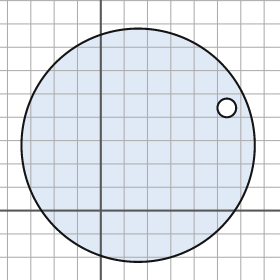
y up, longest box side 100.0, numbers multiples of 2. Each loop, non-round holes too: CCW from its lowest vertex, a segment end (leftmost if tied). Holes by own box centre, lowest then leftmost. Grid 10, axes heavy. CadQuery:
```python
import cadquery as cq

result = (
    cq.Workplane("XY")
    .moveTo(16.0, 28.0)
    .circle(50.0)
    .moveTo(54.0, 44.0)
    .circle(4.0)
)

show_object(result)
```